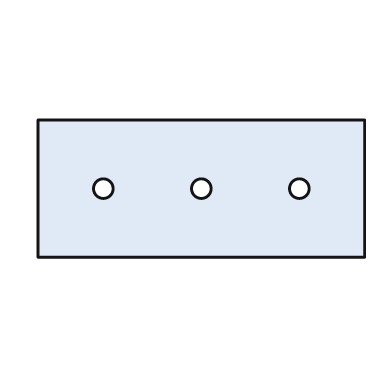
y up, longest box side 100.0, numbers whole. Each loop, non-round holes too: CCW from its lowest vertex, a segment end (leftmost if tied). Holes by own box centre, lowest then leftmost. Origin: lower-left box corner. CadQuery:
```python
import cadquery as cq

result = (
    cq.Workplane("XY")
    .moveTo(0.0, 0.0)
    .lineTo(100.0, 0.0)
    .lineTo(100.0, 42.0)
    .lineTo(0.0, 42.0)
    .close()
    .moveTo(20.0, 21.0)
    .circle(3.0)
    .moveTo(50.0, 21.0)
    .circle(3.0)
    .moveTo(80.0, 21.0)
    .circle(3.0)
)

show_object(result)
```